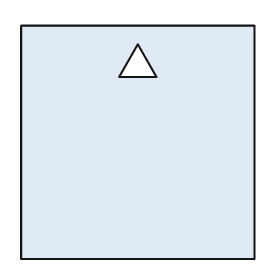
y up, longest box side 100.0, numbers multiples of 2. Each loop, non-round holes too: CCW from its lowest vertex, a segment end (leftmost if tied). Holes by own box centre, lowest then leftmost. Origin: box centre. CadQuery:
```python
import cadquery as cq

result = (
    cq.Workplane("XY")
    .moveTo(-50.0, -50.0)
    .lineTo(50.0, -50.0)
    .lineTo(50.0, 50.0)
    .lineTo(-50.0, 50.0)
    .close()
    .moveTo(-8.0, 28.0)
    .lineTo(8.0, 28.0)
    .lineTo(0.0, 42.0)
    .close()
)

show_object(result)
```